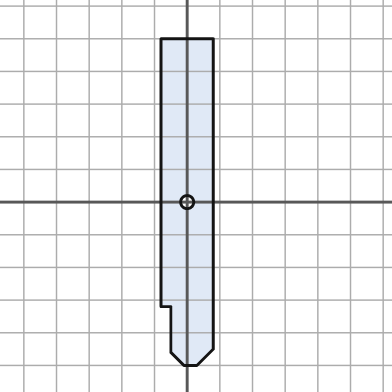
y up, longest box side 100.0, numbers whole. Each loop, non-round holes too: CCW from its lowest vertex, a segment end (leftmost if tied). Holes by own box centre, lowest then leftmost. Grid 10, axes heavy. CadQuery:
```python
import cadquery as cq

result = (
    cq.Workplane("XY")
    .moveTo(-1.0, -50.0)
    .lineTo(3.0, -50.0)
    .lineTo(8.0, -45.0)
    .lineTo(8.0, 50.0)
    .lineTo(-8.0, 50.0)
    .lineTo(-8.0, -32.0)
    .lineTo(-5.0, -32.0)
    .lineTo(-5.0, -46.0)
    .close()
    .moveTo(0.0, 0.0)
    .circle(2.0)
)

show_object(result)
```